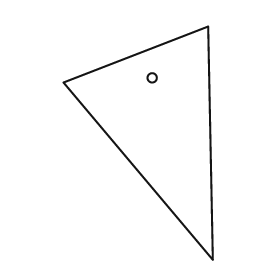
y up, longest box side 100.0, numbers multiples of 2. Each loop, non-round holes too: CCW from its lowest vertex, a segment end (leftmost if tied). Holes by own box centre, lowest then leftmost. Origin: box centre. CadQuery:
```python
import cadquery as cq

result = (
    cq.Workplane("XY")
    .moveTo(32.0, -50.0)
    .lineTo(30.0, 50.0)
    .lineTo(-32.0, 26.0)
    .close()
    .moveTo(6.0, 28.0)
    .circle(2.0)
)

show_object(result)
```